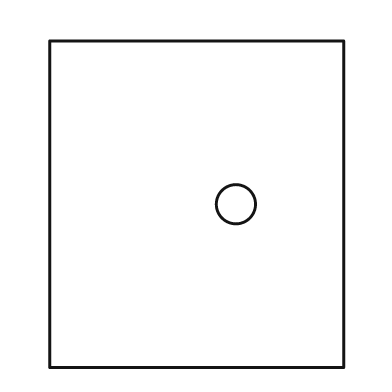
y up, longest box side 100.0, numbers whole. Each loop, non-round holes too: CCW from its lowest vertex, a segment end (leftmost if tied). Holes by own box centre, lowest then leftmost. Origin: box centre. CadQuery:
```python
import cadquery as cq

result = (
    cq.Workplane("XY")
    .moveTo(-45.0, -50.0)
    .lineTo(45.0, -50.0)
    .lineTo(45.0, 50.0)
    .lineTo(-45.0, 50.0)
    .close()
    .moveTo(12.0, 0.0)
    .circle(6.0)
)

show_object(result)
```